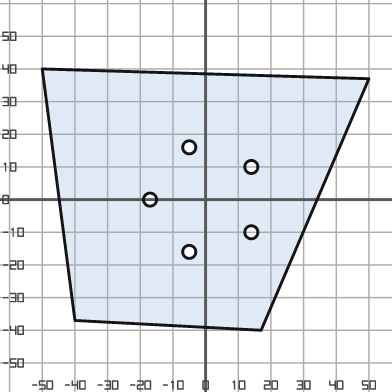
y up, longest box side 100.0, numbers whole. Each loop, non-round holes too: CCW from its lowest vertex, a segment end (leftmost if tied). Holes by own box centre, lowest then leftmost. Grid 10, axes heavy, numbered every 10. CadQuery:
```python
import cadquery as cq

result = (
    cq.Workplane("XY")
    .moveTo(17.0, -40.0)
    .lineTo(50.0, 37.0)
    .lineTo(-50.0, 40.0)
    .lineTo(-40.0, -37.0)
    .close()
    .moveTo(-5.0, -16.0)
    .circle(2.0)
    .moveTo(14.0, -10.0)
    .circle(2.0)
    .moveTo(-17.0, 0.0)
    .circle(2.0)
    .moveTo(14.0, 10.0)
    .circle(2.0)
    .moveTo(-5.0, 16.0)
    .circle(2.0)
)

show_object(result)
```